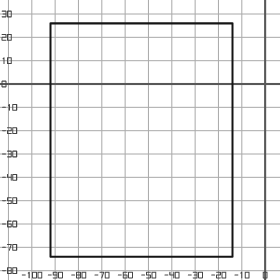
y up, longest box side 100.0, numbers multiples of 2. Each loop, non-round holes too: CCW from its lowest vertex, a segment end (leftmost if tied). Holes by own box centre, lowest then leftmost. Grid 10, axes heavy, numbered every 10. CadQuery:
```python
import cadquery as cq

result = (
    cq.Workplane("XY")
    .moveTo(-92.0, -74.0)
    .lineTo(-14.0, -74.0)
    .lineTo(-14.0, 26.0)
    .lineTo(-92.0, 26.0)
    .close()
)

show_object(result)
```